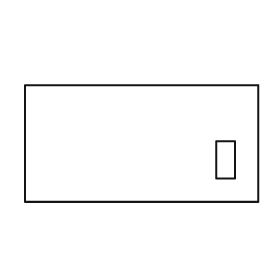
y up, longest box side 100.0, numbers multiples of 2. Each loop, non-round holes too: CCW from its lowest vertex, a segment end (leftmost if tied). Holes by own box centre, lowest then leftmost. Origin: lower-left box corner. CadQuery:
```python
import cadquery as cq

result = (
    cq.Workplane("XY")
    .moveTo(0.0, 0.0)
    .lineTo(100.0, 0.0)
    .lineTo(100.0, 50.0)
    .lineTo(0.0, 50.0)
    .close()
    .moveTo(82.0, 10.0)
    .lineTo(90.0, 10.0)
    .lineTo(90.0, 26.0)
    .lineTo(82.0, 26.0)
    .close()
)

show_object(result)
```